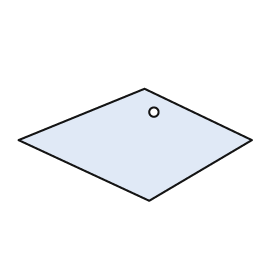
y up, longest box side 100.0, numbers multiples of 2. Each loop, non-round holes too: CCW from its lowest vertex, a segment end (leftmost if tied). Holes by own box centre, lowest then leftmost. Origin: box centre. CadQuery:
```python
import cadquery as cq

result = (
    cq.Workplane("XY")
    .moveTo(6.0, -24.0)
    .lineTo(50.0, 2.0)
    .lineTo(4.0, 24.0)
    .lineTo(-50.0, 2.0)
    .close()
    .moveTo(8.0, 14.0)
    .circle(2.0)
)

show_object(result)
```